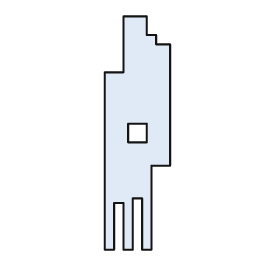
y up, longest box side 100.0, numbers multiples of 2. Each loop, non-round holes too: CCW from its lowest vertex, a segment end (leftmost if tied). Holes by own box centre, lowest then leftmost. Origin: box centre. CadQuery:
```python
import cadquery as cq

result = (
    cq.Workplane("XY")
    .moveTo(-14.0, -50.0)
    .lineTo(-10.0, -50.0)
    .lineTo(-10.0, -30.0)
    .lineTo(-6.0, -30.0)
    .lineTo(-6.0, -50.0)
    .lineTo(-2.0, -50.0)
    .lineTo(-2.0, -28.0)
    .lineTo(2.0, -28.0)
    .lineTo(2.0, -50.0)
    .lineTo(6.0, -50.0)
    .lineTo(6.0, -14.0)
    .lineTo(14.0, -14.0)
    .lineTo(14.0, 38.0)
    .lineTo(8.0, 38.0)
    .lineTo(8.0, 42.0)
    .lineTo(4.0, 42.0)
    .lineTo(4.0, 50.0)
    .lineTo(-6.0, 50.0)
    .lineTo(-6.0, 26.0)
    .lineTo(-14.0, 26.0)
    .close()
    .moveTo(-4.0, -4.0)
    .lineTo(4.0, -4.0)
    .lineTo(4.0, 4.0)
    .lineTo(-4.0, 4.0)
    .close()
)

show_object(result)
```